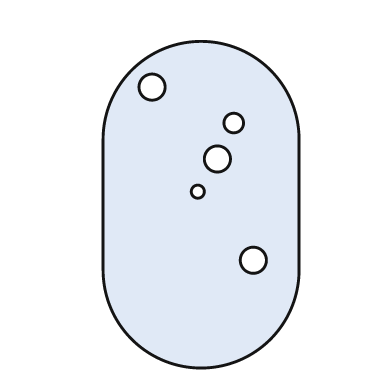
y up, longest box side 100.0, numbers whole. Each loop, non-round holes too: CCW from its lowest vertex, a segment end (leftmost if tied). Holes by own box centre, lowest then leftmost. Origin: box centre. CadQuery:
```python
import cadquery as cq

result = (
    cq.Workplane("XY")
    .moveTo(-30.0, -20.0)
    .threePointArc((0.0, -50.0), (30.0, -20.0))
    .lineTo(30.0, 20.0)
    .threePointArc((0.0, 50.0), (-30.0, 20.0))
    .close()
    .moveTo(16.0, -17.0)
    .circle(4.0)
    .moveTo(-1.0, 4.0)
    .circle(2.0)
    .moveTo(5.0, 14.0)
    .circle(4.0)
    .moveTo(10.0, 25.0)
    .circle(3.0)
    .moveTo(-15.0, 36.0)
    .circle(4.0)
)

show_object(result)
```